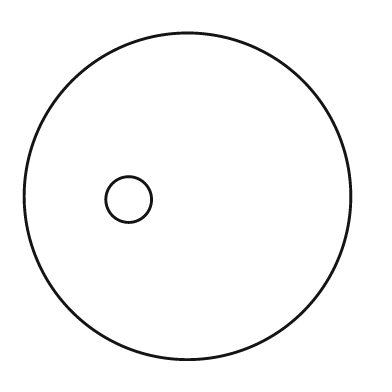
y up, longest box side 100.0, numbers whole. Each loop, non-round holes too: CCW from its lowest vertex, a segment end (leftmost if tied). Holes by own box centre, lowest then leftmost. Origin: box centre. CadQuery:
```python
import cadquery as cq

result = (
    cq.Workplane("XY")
    .moveTo(0.0, 0.0)
    .circle(50.0)
    .moveTo(-18.0, -1.0)
    .circle(7.0)
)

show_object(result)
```